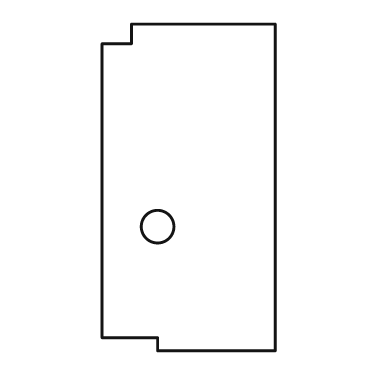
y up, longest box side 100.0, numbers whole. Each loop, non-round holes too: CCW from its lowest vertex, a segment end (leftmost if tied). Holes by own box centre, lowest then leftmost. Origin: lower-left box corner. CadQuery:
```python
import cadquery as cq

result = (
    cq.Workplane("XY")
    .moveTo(17.0, 0.0)
    .lineTo(53.0, 0.0)
    .lineTo(53.0, 100.0)
    .lineTo(9.0, 100.0)
    .lineTo(9.0, 94.0)
    .lineTo(0.0, 94.0)
    .lineTo(0.0, 4.0)
    .lineTo(17.0, 4.0)
    .close()
    .moveTo(17.0, 38.0)
    .circle(5.0)
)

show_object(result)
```